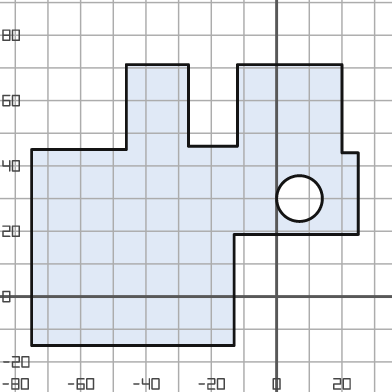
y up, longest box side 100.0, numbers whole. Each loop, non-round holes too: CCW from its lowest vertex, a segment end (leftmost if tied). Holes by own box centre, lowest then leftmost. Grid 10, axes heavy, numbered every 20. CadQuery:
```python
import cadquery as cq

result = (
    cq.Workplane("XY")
    .moveTo(-75.0, -15.0)
    .lineTo(-13.0, -15.0)
    .lineTo(-13.0, 19.0)
    .lineTo(25.0, 19.0)
    .lineTo(25.0, 44.0)
    .lineTo(20.0, 44.0)
    .lineTo(20.0, 71.0)
    .lineTo(-12.0, 71.0)
    .lineTo(-12.0, 46.0)
    .lineTo(-27.0, 46.0)
    .lineTo(-27.0, 71.0)
    .lineTo(-46.0, 71.0)
    .lineTo(-46.0, 45.0)
    .lineTo(-75.0, 45.0)
    .close()
    .moveTo(7.0, 30.0)
    .circle(7.0)
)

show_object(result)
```